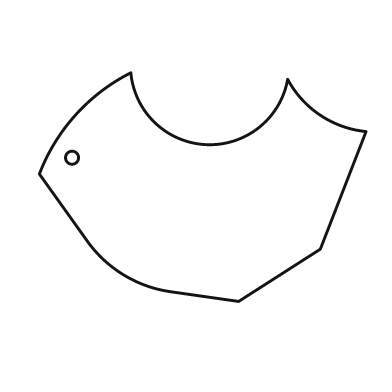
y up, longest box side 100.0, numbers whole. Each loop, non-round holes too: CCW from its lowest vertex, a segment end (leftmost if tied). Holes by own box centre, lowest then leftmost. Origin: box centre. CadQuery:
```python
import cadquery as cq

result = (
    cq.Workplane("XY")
    .moveTo(11.0, -35.0)
    .lineTo(36.0, -19.0)
    .lineTo(50.0, 17.0)
    .threePointArc((36.0, 22.0), (26.0, 33.0))
    .threePointArc((1.0, 13.0), (-22.0, 35.0))
    .threePointArc((-39.0, 22.0), (-50.0, 4.0))
    .lineTo(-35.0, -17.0)
    .threePointArc((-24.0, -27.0), (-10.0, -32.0))
    .close()
    .moveTo(-40.0, 9.0)
    .circle(2.0)
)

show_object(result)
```